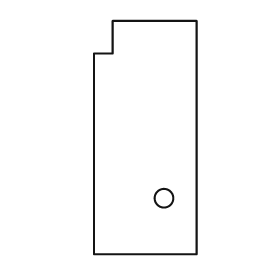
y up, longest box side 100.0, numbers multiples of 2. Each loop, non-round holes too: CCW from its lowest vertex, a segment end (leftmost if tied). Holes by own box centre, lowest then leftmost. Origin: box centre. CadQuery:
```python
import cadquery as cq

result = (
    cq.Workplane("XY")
    .moveTo(-22.0, -50.0)
    .lineTo(22.0, -50.0)
    .lineTo(22.0, 50.0)
    .lineTo(-14.0, 50.0)
    .lineTo(-14.0, 36.0)
    .lineTo(-22.0, 36.0)
    .close()
    .moveTo(8.0, -26.0)
    .circle(4.0)
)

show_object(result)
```